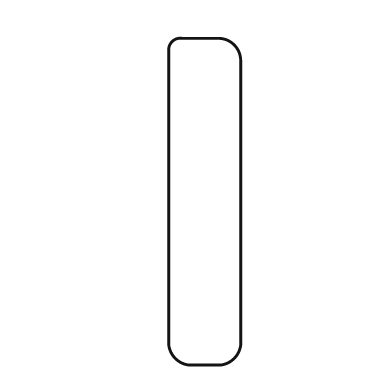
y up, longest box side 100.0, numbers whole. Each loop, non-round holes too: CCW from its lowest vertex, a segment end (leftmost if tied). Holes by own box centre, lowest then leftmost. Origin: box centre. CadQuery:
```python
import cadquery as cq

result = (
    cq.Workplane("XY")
    .moveTo(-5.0, -50.0)
    .lineTo(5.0, -50.0)
    .threePointArc((9.0, -48.0), (11.0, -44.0))
    .lineTo(11.0, 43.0)
    .threePointArc((9.0, 48.0), (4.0, 50.0))
    .lineTo(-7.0, 50.0)
    .threePointArc((-10.0, 49.0), (-11.0, 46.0))
    .lineTo(-11.0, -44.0)
    .threePointArc((-9.0, -48.0), (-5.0, -50.0))
    .close()
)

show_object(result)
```